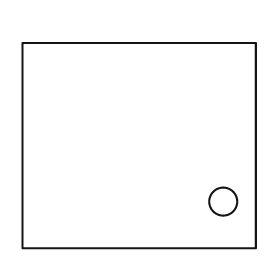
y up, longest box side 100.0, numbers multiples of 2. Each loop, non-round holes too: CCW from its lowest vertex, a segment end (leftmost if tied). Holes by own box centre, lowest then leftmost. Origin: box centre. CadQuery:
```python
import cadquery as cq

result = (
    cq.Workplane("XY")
    .moveTo(-50.0, -44.0)
    .lineTo(50.0, -44.0)
    .lineTo(50.0, 44.0)
    .lineTo(-50.0, 44.0)
    .close()
    .moveTo(36.0, -24.0)
    .circle(6.0)
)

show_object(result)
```